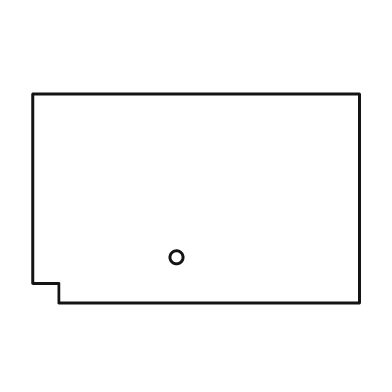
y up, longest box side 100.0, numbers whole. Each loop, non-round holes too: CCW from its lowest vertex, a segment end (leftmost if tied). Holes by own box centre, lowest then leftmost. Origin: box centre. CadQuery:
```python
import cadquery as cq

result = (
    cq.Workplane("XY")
    .moveTo(-42.0, -32.0)
    .lineTo(50.0, -32.0)
    .lineTo(50.0, 32.0)
    .lineTo(-50.0, 32.0)
    .lineTo(-50.0, -26.0)
    .lineTo(-42.0, -26.0)
    .close()
    .moveTo(-6.0, -18.0)
    .circle(2.0)
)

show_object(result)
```